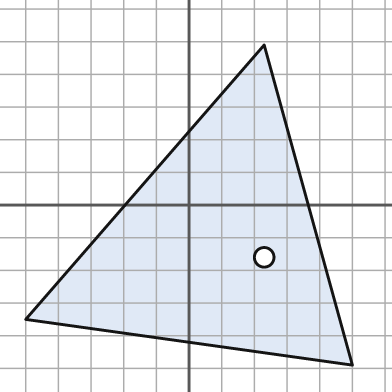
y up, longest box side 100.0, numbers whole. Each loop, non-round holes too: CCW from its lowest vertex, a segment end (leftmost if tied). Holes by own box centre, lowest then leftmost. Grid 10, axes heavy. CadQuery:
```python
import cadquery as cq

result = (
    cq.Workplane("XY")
    .moveTo(50.0, -49.0)
    .lineTo(23.0, 49.0)
    .lineTo(-50.0, -35.0)
    .close()
    .moveTo(23.0, -16.0)
    .circle(3.0)
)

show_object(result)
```